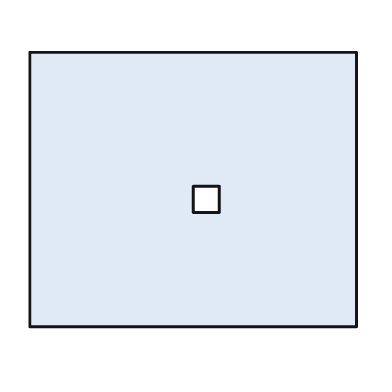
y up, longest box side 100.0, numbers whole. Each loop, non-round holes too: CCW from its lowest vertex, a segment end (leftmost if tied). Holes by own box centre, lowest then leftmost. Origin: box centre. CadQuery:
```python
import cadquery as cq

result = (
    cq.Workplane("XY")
    .moveTo(-50.0, -42.0)
    .lineTo(50.0, -42.0)
    .lineTo(50.0, 42.0)
    .lineTo(-50.0, 42.0)
    .close()
    .moveTo(0.0, -7.0)
    .lineTo(8.0, -7.0)
    .lineTo(8.0, 1.0)
    .lineTo(0.0, 1.0)
    .close()
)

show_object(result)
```